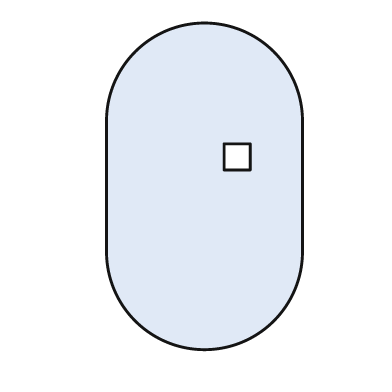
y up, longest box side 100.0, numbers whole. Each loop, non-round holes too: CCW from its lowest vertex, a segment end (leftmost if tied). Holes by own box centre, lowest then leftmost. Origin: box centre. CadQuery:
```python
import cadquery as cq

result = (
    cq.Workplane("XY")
    .moveTo(-30.0, -20.0)
    .threePointArc((0.0, -50.0), (30.0, -20.0))
    .lineTo(30.0, 20.0)
    .threePointArc((0.0, 50.0), (-30.0, 20.0))
    .close()
    .moveTo(6.0, 5.0)
    .lineTo(14.0, 5.0)
    .lineTo(14.0, 13.0)
    .lineTo(6.0, 13.0)
    .close()
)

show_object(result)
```